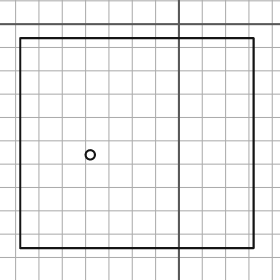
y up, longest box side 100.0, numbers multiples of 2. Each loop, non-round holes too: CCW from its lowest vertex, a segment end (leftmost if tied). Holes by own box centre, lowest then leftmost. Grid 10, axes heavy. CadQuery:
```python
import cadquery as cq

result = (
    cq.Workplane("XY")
    .moveTo(-68.0, -96.0)
    .lineTo(32.0, -96.0)
    .lineTo(32.0, -6.0)
    .lineTo(-68.0, -6.0)
    .close()
    .moveTo(-38.0, -56.0)
    .circle(2.0)
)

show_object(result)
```